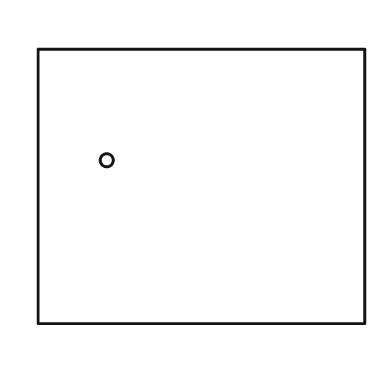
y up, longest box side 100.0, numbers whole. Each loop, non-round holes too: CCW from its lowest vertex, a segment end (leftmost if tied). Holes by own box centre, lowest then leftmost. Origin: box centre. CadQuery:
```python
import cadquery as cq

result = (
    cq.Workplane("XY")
    .moveTo(-50.0, -42.0)
    .lineTo(50.0, -42.0)
    .lineTo(50.0, 42.0)
    .lineTo(-50.0, 42.0)
    .close()
    .moveTo(-29.0, 8.0)
    .circle(2.0)
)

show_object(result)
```